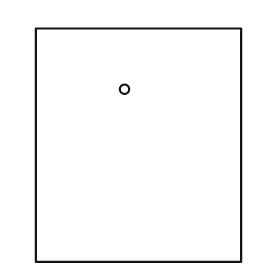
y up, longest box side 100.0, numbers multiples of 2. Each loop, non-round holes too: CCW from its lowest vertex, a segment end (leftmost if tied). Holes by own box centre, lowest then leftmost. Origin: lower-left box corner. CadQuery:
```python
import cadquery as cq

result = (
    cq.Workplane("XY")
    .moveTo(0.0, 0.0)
    .lineTo(88.0, 0.0)
    .lineTo(88.0, 100.0)
    .lineTo(0.0, 100.0)
    .close()
    .moveTo(38.0, 74.0)
    .circle(2.0)
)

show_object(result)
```